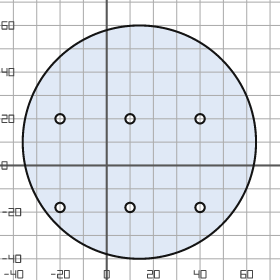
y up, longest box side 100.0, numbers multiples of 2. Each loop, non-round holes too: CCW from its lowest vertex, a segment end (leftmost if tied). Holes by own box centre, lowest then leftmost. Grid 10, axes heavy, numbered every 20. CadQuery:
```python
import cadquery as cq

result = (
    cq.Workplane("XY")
    .moveTo(14.0, 10.0)
    .circle(50.0)
    .moveTo(-20.0, -18.0)
    .circle(2.0)
    .moveTo(10.0, -18.0)
    .circle(2.0)
    .moveTo(40.0, -18.0)
    .circle(2.0)
    .moveTo(-20.0, 20.0)
    .circle(2.0)
    .moveTo(10.0, 20.0)
    .circle(2.0)
    .moveTo(40.0, 20.0)
    .circle(2.0)
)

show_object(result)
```